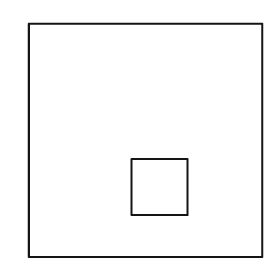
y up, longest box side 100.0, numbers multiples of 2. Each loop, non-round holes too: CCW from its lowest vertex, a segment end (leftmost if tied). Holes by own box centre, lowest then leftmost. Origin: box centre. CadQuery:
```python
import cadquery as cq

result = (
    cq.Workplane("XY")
    .moveTo(-50.0, -50.0)
    .lineTo(50.0, -50.0)
    .lineTo(50.0, 50.0)
    .lineTo(-50.0, 50.0)
    .close()
    .moveTo(-6.0, -32.0)
    .lineTo(18.0, -32.0)
    .lineTo(18.0, -8.0)
    .lineTo(-6.0, -8.0)
    .close()
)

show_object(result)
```